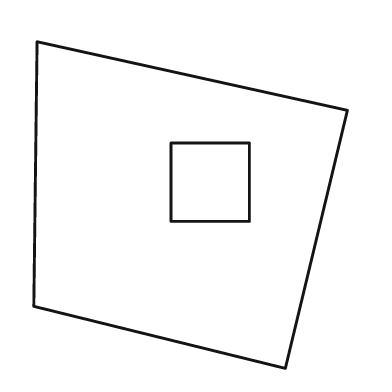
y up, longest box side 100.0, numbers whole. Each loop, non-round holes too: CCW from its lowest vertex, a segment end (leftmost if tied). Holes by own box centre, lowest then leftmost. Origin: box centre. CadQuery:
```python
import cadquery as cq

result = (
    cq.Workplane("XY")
    .moveTo(29.0, -50.0)
    .lineTo(48.0, 29.0)
    .lineTo(-47.0, 50.0)
    .lineTo(-48.0, -31.0)
    .close()
    .moveTo(-6.0, -5.0)
    .lineTo(18.0, -5.0)
    .lineTo(18.0, 19.0)
    .lineTo(-6.0, 19.0)
    .close()
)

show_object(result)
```